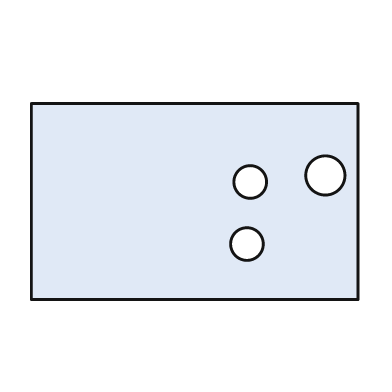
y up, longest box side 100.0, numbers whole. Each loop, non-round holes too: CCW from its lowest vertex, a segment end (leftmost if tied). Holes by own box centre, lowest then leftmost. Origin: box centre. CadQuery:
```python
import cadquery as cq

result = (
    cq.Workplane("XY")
    .moveTo(-50.0, -30.0)
    .lineTo(50.0, -30.0)
    .lineTo(50.0, 30.0)
    .lineTo(-50.0, 30.0)
    .close()
    .moveTo(16.0, -13.0)
    .circle(5.0)
    .moveTo(17.0, 6.0)
    .circle(5.0)
    .moveTo(40.0, 8.0)
    .circle(6.0)
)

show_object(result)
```